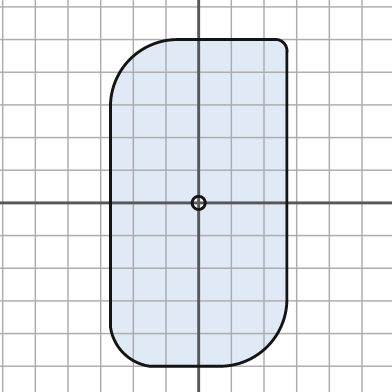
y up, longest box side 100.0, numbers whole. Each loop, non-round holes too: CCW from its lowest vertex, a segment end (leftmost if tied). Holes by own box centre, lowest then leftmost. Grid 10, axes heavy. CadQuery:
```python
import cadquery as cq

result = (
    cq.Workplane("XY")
    .moveTo(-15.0, -50.0)
    .lineTo(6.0, -50.0)
    .threePointArc((21.0, -44.0), (27.0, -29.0))
    .lineTo(27.0, 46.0)
    .threePointArc((26.0, 49.0), (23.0, 50.0))
    .lineTo(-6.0, 50.0)
    .threePointArc((-21.0, 44.0), (-27.0, 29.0))
    .lineTo(-27.0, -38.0)
    .threePointArc((-23.0, -46.0), (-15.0, -50.0))
    .close()
    .moveTo(0.0, 0.0)
    .circle(2.0)
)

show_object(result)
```